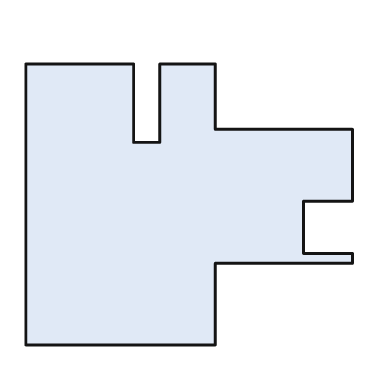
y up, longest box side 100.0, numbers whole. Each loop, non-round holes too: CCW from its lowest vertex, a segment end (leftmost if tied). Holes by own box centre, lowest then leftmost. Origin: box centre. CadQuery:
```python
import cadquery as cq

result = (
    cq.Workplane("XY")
    .moveTo(-50.0, -43.0)
    .lineTo(8.0, -43.0)
    .lineTo(8.0, -18.0)
    .lineTo(50.0, -18.0)
    .lineTo(50.0, -15.0)
    .lineTo(35.0, -15.0)
    .lineTo(35.0, 1.0)
    .lineTo(50.0, 1.0)
    .lineTo(50.0, 23.0)
    .lineTo(8.0, 23.0)
    .lineTo(8.0, 43.0)
    .lineTo(-9.0, 43.0)
    .lineTo(-9.0, 19.0)
    .lineTo(-17.0, 19.0)
    .lineTo(-17.0, 43.0)
    .lineTo(-50.0, 43.0)
    .close()
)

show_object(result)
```